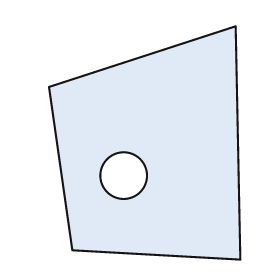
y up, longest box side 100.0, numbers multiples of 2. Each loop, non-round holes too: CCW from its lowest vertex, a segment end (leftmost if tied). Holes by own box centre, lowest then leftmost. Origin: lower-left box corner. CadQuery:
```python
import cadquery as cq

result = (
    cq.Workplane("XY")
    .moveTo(82.0, 0.0)
    .lineTo(80.0, 100.0)
    .lineTo(0.0, 74.0)
    .lineTo(10.0, 4.0)
    .close()
    .moveTo(32.0, 36.0)
    .circle(10.0)
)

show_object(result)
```